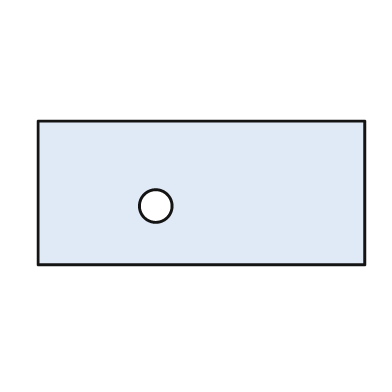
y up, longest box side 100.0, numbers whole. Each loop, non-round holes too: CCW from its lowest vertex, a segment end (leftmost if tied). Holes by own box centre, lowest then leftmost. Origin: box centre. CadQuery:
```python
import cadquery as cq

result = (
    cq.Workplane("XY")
    .moveTo(-50.0, -22.0)
    .lineTo(50.0, -22.0)
    .lineTo(50.0, 22.0)
    .lineTo(-50.0, 22.0)
    .close()
    .moveTo(-14.0, -4.0)
    .circle(5.0)
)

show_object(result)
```